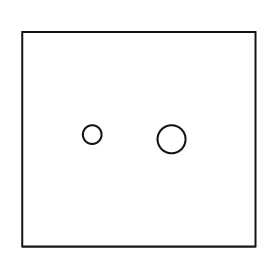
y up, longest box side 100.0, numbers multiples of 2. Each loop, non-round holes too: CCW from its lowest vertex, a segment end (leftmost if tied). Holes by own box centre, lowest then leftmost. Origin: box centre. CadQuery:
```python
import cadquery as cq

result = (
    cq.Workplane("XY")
    .moveTo(-50.0, -46.0)
    .lineTo(50.0, -46.0)
    .lineTo(50.0, 46.0)
    .lineTo(-50.0, 46.0)
    .close()
    .moveTo(14.0, 0.0)
    .circle(6.0)
    .moveTo(-20.0, 2.0)
    .circle(4.0)
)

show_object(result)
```